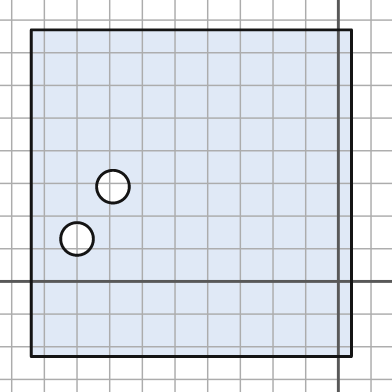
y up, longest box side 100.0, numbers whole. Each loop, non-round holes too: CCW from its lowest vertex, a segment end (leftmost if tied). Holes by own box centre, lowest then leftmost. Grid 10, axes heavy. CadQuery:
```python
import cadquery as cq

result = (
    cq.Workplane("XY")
    .moveTo(-94.0, -23.0)
    .lineTo(4.0, -23.0)
    .lineTo(4.0, 77.0)
    .lineTo(-94.0, 77.0)
    .close()
    .moveTo(-80.0, 13.0)
    .circle(5.0)
    .moveTo(-69.0, 29.0)
    .circle(5.0)
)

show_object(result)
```